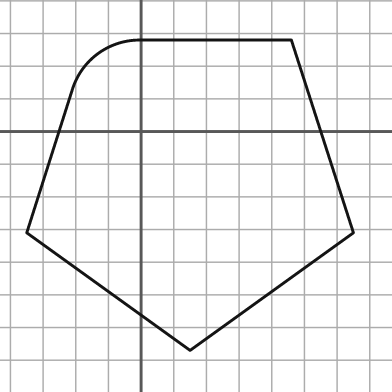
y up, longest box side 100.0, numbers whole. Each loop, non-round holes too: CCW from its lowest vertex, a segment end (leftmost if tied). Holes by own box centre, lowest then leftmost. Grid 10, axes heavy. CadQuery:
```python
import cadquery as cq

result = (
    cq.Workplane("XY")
    .moveTo(15.0, -67.0)
    .lineTo(65.0, -31.0)
    .lineTo(46.0, 28.0)
    .lineTo(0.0, 28.0)
    .threePointArc((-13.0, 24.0), (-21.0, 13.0))
    .lineTo(-35.0, -31.0)
    .close()
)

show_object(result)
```